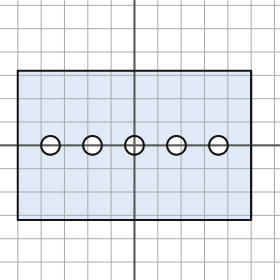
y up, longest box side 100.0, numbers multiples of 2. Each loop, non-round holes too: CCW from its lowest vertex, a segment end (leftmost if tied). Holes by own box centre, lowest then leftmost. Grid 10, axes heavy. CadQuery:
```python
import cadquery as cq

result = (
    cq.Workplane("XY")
    .moveTo(-50.0, -32.0)
    .lineTo(50.0, -32.0)
    .lineTo(50.0, 32.0)
    .lineTo(-50.0, 32.0)
    .close()
    .moveTo(-36.0, 0.0)
    .circle(4.0)
    .moveTo(-18.0, 0.0)
    .circle(4.0)
    .moveTo(0.0, 0.0)
    .circle(4.0)
    .moveTo(18.0, 0.0)
    .circle(4.0)
    .moveTo(36.0, 0.0)
    .circle(4.0)
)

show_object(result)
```